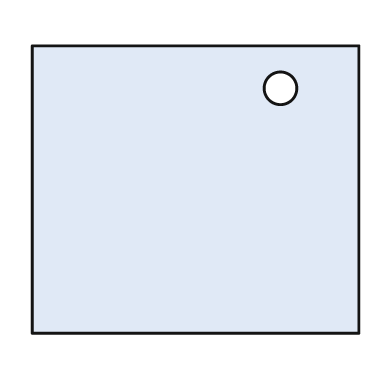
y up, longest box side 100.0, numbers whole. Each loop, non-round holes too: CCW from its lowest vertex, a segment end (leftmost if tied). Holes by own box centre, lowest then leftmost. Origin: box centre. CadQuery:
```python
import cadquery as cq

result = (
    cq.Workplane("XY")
    .moveTo(-50.0, -44.0)
    .lineTo(50.0, -44.0)
    .lineTo(50.0, 44.0)
    .lineTo(-50.0, 44.0)
    .close()
    .moveTo(26.0, 31.0)
    .circle(5.0)
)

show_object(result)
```